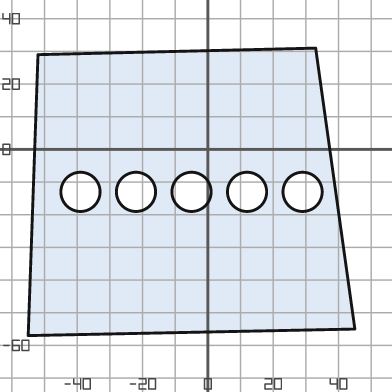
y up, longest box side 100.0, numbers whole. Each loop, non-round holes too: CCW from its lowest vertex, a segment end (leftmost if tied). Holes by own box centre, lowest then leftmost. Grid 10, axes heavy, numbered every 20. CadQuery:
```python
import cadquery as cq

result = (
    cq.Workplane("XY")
    .moveTo(-55.0, -57.0)
    .lineTo(45.0, -55.0)
    .lineTo(33.0, 31.0)
    .lineTo(-52.0, 29.0)
    .close()
    .moveTo(-39.0, -13.0)
    .circle(6.0)
    .moveTo(-22.0, -13.0)
    .circle(6.0)
    .moveTo(-5.0, -13.0)
    .circle(6.0)
    .moveTo(12.0, -13.0)
    .circle(6.0)
    .moveTo(29.0, -13.0)
    .circle(6.0)
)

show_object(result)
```